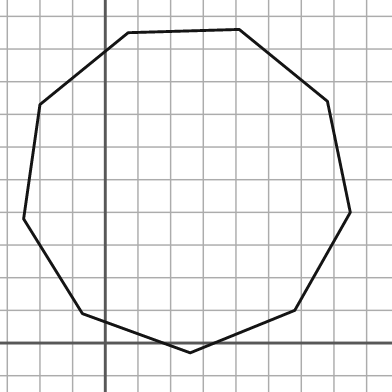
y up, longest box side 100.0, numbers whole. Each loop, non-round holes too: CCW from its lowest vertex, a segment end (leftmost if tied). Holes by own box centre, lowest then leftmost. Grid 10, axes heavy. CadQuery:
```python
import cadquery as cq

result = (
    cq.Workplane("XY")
    .moveTo(26.0, -3.0)
    .lineTo(58.0, 10.0)
    .lineTo(75.0, 40.0)
    .lineTo(68.0, 74.0)
    .lineTo(41.0, 96.0)
    .lineTo(7.0, 95.0)
    .lineTo(-20.0, 73.0)
    .lineTo(-25.0, 38.0)
    .lineTo(-7.0, 9.0)
    .close()
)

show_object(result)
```